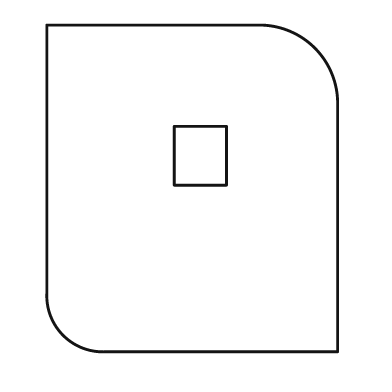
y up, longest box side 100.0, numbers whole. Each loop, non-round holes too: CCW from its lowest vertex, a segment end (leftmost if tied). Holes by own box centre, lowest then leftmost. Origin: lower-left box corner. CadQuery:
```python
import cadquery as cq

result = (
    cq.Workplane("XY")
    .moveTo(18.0, 0.0)
    .lineTo(89.0, 0.0)
    .lineTo(89.0, 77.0)
    .threePointArc((82.0, 93.0), (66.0, 100.0))
    .lineTo(0.0, 100.0)
    .lineTo(0.0, 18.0)
    .threePointArc((5.0, 5.0), (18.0, 0.0))
    .close()
    .moveTo(39.0, 51.0)
    .lineTo(55.0, 51.0)
    .lineTo(55.0, 69.0)
    .lineTo(39.0, 69.0)
    .close()
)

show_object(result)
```